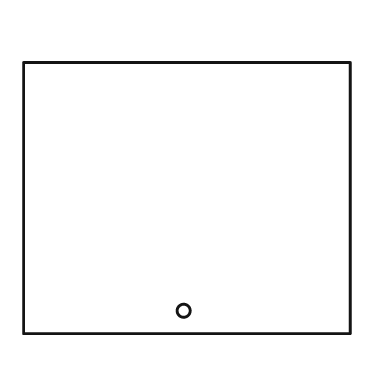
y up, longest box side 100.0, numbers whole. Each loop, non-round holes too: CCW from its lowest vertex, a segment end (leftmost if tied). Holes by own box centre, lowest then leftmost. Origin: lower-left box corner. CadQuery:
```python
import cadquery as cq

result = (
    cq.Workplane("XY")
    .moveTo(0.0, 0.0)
    .lineTo(100.0, 0.0)
    .lineTo(100.0, 83.0)
    .lineTo(0.0, 83.0)
    .close()
    .moveTo(49.0, 7.0)
    .circle(2.0)
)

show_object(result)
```